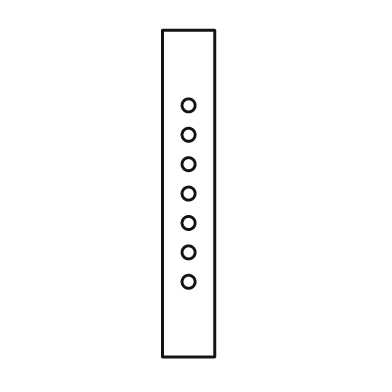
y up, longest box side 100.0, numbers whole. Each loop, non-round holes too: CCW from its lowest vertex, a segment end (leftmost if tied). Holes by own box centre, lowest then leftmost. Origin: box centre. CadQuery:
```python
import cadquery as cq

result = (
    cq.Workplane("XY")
    .moveTo(-8.0, -50.0)
    .lineTo(8.0, -50.0)
    .lineTo(8.0, 50.0)
    .lineTo(-8.0, 50.0)
    .close()
    .moveTo(0.0, -27.0)
    .circle(2.0)
    .moveTo(0.0, -18.0)
    .circle(2.0)
    .moveTo(0.0, -9.0)
    .circle(2.0)
    .moveTo(0.0, 0.0)
    .circle(2.0)
    .moveTo(0.0, 9.0)
    .circle(2.0)
    .moveTo(0.0, 18.0)
    .circle(2.0)
    .moveTo(0.0, 27.0)
    .circle(2.0)
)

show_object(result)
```